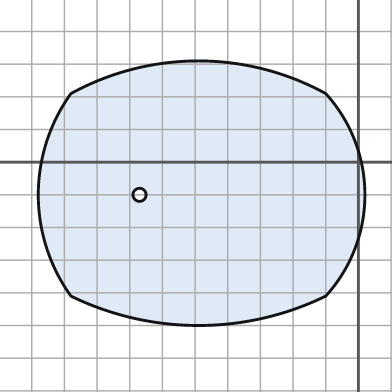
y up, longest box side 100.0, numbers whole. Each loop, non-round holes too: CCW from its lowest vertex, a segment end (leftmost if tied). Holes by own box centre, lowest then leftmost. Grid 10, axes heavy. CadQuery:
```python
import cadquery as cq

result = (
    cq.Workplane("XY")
    .moveTo(-88.0, -41.0)
    .threePointArc((-49.0, -50.0), (-10.0, -41.0))
    .threePointArc((2.0, -10.0), (-10.0, 21.0))
    .threePointArc((-49.0, 31.0), (-88.0, 21.0))
    .threePointArc((-98.0, -10.0), (-88.0, -41.0))
    .close()
    .moveTo(-67.0, -10.0)
    .circle(2.0)
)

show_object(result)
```